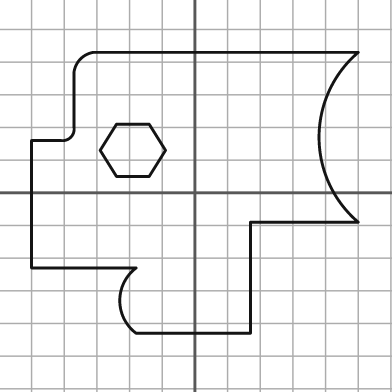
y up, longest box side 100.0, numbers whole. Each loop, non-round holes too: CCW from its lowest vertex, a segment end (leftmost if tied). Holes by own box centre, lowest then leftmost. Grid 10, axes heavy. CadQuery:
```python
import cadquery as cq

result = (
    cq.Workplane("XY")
    .moveTo(-18.0, -43.0)
    .lineTo(17.0, -43.0)
    .lineTo(17.0, -9.0)
    .lineTo(50.0, -9.0)
    .threePointArc((38.0, 17.0), (50.0, 43.0))
    .lineTo(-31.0, 43.0)
    .threePointArc((-35.0, 41.0), (-37.0, 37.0))
    .lineTo(-37.0, 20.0)
    .threePointArc((-38.0, 17.0), (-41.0, 16.0))
    .lineTo(-50.0, 16.0)
    .lineTo(-50.0, -23.0)
    .lineTo(-18.0, -23.0)
    .threePointArc((-23.0, -33.0), (-18.0, -43.0))
    .close()
    .moveTo(-24.0, 5.0)
    .lineTo(-14.0, 5.0)
    .lineTo(-9.0, 13.0)
    .lineTo(-14.0, 21.0)
    .lineTo(-24.0, 21.0)
    .lineTo(-29.0, 13.0)
    .close()
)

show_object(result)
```